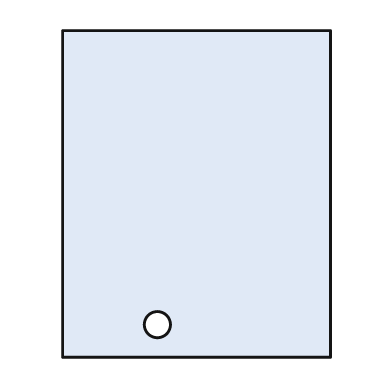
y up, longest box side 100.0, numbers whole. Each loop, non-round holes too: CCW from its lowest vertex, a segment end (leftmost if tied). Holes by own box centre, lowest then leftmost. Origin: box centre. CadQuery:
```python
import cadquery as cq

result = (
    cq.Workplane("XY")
    .moveTo(-41.0, -50.0)
    .lineTo(41.0, -50.0)
    .lineTo(41.0, 50.0)
    .lineTo(-41.0, 50.0)
    .close()
    .moveTo(-12.0, -40.0)
    .circle(4.0)
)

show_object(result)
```